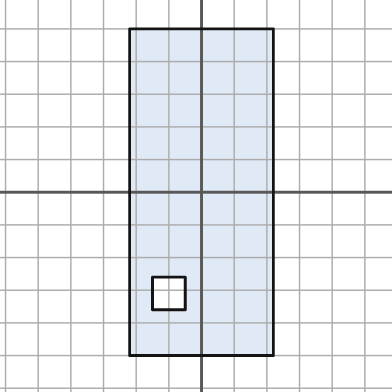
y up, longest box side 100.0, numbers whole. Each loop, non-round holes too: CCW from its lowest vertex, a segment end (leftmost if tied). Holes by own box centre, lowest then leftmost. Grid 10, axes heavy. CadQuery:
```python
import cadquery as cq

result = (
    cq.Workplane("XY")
    .moveTo(-22.0, -50.0)
    .lineTo(22.0, -50.0)
    .lineTo(22.0, 50.0)
    .lineTo(-22.0, 50.0)
    .close()
    .moveTo(-15.0, -36.0)
    .lineTo(-5.0, -36.0)
    .lineTo(-5.0, -26.0)
    .lineTo(-15.0, -26.0)
    .close()
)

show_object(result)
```